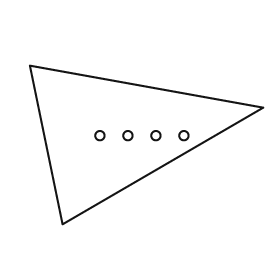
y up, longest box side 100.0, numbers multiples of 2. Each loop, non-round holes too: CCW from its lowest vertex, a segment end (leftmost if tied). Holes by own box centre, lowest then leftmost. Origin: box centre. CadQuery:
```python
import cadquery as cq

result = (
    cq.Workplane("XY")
    .moveTo(-36.0, -34.0)
    .lineTo(50.0, 16.0)
    .lineTo(-50.0, 34.0)
    .close()
    .moveTo(-20.0, 4.0)
    .circle(2.0)
    .moveTo(-8.0, 4.0)
    .circle(2.0)
    .moveTo(4.0, 4.0)
    .circle(2.0)
    .moveTo(16.0, 4.0)
    .circle(2.0)
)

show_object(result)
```